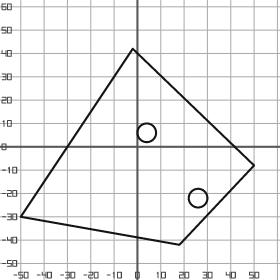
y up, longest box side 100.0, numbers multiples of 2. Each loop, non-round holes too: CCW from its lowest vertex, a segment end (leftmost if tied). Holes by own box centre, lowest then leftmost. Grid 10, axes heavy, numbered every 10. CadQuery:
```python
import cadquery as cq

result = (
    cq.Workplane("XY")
    .moveTo(18.0, -42.0)
    .lineTo(50.0, -8.0)
    .lineTo(-2.0, 42.0)
    .lineTo(-50.0, -30.0)
    .close()
    .moveTo(26.0, -22.0)
    .circle(4.0)
    .moveTo(4.0, 6.0)
    .circle(4.0)
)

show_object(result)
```